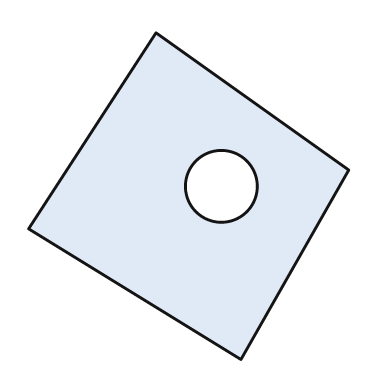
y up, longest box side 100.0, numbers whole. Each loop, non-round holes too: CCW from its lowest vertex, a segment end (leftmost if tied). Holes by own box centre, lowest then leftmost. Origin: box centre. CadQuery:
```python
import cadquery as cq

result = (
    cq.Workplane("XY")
    .moveTo(16.0, -50.0)
    .lineTo(49.0, 8.0)
    .lineTo(-10.0, 50.0)
    .lineTo(-49.0, -10.0)
    .close()
    .moveTo(10.0, 3.0)
    .circle(11.0)
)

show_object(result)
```